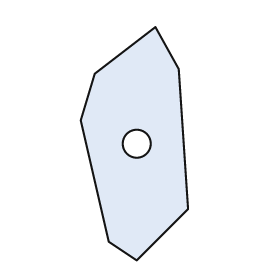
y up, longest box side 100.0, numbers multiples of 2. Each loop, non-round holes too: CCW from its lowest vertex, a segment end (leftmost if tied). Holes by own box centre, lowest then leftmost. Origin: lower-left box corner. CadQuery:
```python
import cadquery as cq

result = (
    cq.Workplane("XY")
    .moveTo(24.0, 0.0)
    .lineTo(46.0, 22.0)
    .lineTo(42.0, 82.0)
    .lineTo(32.0, 100.0)
    .lineTo(6.0, 80.0)
    .lineTo(0.0, 60.0)
    .lineTo(12.0, 8.0)
    .close()
    .moveTo(24.0, 50.0)
    .circle(6.0)
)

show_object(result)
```